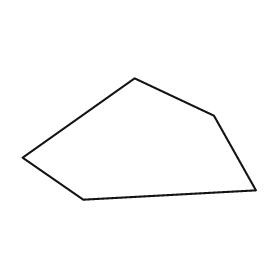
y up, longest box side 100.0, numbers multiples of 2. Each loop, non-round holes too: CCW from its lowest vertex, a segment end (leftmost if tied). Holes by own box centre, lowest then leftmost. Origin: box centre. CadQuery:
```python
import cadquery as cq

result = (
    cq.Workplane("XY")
    .moveTo(-24.0, -26.0)
    .lineTo(50.0, -22.0)
    .lineTo(32.0, 10.0)
    .lineTo(-2.0, 26.0)
    .lineTo(-50.0, -8.0)
    .close()
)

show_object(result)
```